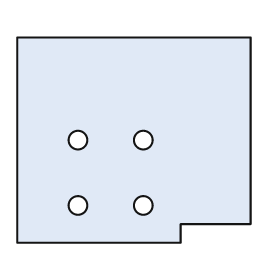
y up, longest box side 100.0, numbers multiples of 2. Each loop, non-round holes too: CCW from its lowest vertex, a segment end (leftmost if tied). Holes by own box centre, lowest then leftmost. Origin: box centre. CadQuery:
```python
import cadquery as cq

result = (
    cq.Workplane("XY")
    .moveTo(-50.0, -44.0)
    .lineTo(20.0, -44.0)
    .lineTo(20.0, -36.0)
    .lineTo(50.0, -36.0)
    .lineTo(50.0, 44.0)
    .lineTo(-50.0, 44.0)
    .close()
    .moveTo(-24.0, -28.0)
    .circle(4.0)
    .moveTo(4.0, -28.0)
    .circle(4.0)
    .moveTo(-24.0, 0.0)
    .circle(4.0)
    .moveTo(4.0, 0.0)
    .circle(4.0)
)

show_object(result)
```